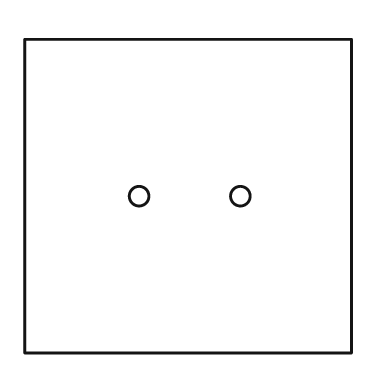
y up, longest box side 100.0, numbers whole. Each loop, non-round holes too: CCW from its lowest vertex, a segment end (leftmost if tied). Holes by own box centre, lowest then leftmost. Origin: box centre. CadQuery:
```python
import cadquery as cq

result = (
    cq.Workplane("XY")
    .moveTo(-50.0, -48.0)
    .lineTo(50.0, -48.0)
    .lineTo(50.0, 48.0)
    .lineTo(-50.0, 48.0)
    .close()
    .moveTo(-15.0, 0.0)
    .circle(3.0)
    .moveTo(16.0, 0.0)
    .circle(3.0)
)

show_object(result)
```